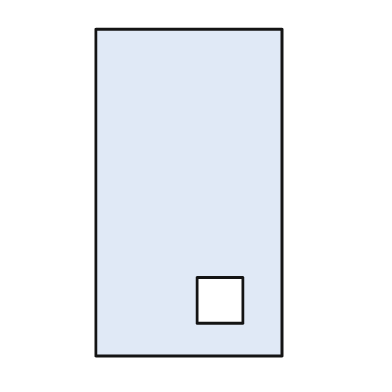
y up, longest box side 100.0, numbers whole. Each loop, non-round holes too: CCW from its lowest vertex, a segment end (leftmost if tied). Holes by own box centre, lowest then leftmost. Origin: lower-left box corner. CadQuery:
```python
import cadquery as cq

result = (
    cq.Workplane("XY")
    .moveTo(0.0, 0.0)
    .lineTo(57.0, 0.0)
    .lineTo(57.0, 100.0)
    .lineTo(0.0, 100.0)
    .close()
    .moveTo(31.0, 10.0)
    .lineTo(45.0, 10.0)
    .lineTo(45.0, 24.0)
    .lineTo(31.0, 24.0)
    .close()
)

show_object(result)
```